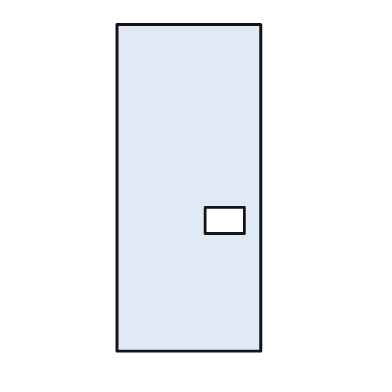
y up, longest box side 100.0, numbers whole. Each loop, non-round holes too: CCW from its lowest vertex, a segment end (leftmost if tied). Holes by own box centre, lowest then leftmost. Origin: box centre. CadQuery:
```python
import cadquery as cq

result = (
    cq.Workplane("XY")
    .moveTo(-22.0, -50.0)
    .lineTo(22.0, -50.0)
    .lineTo(22.0, 50.0)
    .lineTo(-22.0, 50.0)
    .close()
    .moveTo(5.0, -14.0)
    .lineTo(17.0, -14.0)
    .lineTo(17.0, -6.0)
    .lineTo(5.0, -6.0)
    .close()
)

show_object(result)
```